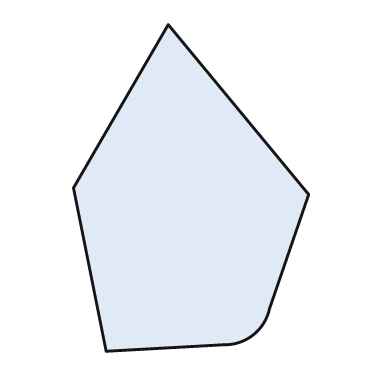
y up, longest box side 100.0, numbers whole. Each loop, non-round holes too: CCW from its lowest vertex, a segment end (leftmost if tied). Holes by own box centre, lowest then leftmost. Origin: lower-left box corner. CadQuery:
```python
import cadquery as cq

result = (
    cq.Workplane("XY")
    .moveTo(10.0, 0.0)
    .lineTo(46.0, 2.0)
    .threePointArc((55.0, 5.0), (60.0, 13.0))
    .lineTo(72.0, 48.0)
    .lineTo(29.0, 100.0)
    .lineTo(0.0, 50.0)
    .close()
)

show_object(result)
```